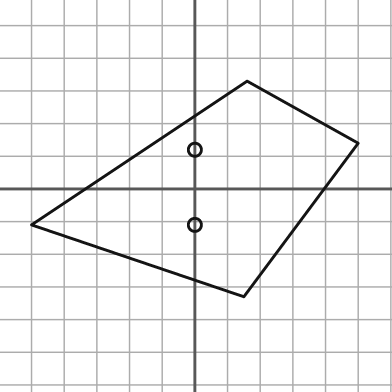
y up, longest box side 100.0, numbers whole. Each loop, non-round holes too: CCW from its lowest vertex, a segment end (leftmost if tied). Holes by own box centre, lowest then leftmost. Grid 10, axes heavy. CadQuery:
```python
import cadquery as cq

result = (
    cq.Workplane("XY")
    .moveTo(15.0, -33.0)
    .lineTo(50.0, 14.0)
    .lineTo(16.0, 33.0)
    .lineTo(-50.0, -11.0)
    .close()
    .moveTo(0.0, -11.0)
    .circle(2.0)
    .moveTo(0.0, 12.0)
    .circle(2.0)
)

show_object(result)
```